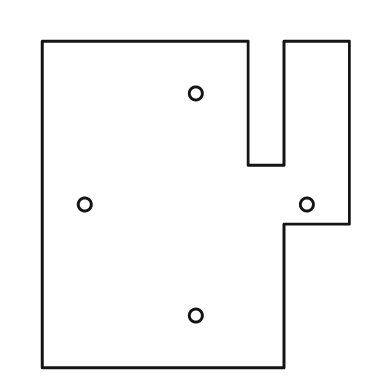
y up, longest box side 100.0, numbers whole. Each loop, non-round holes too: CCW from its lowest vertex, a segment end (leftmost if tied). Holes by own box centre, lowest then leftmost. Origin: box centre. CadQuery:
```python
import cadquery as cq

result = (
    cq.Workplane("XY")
    .moveTo(-47.0, -50.0)
    .lineTo(27.0, -50.0)
    .lineTo(27.0, -6.0)
    .lineTo(47.0, -6.0)
    .lineTo(47.0, 50.0)
    .lineTo(27.0, 50.0)
    .lineTo(27.0, 12.0)
    .lineTo(16.0, 12.0)
    .lineTo(16.0, 50.0)
    .lineTo(-47.0, 50.0)
    .close()
    .moveTo(0.0, -34.0)
    .circle(2.0)
    .moveTo(-34.0, 0.0)
    .circle(2.0)
    .moveTo(34.0, 0.0)
    .circle(2.0)
    .moveTo(0.0, 34.0)
    .circle(2.0)
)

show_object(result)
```